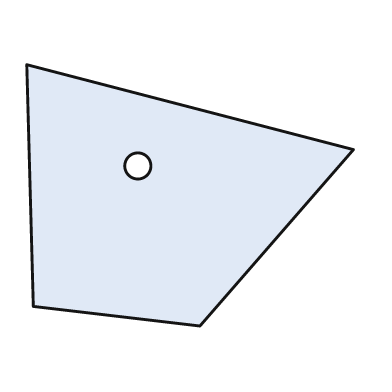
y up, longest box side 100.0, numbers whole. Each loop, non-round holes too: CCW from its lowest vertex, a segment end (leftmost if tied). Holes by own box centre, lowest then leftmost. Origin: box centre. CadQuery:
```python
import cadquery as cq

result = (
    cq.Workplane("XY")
    .moveTo(3.0, -40.0)
    .lineTo(50.0, 14.0)
    .lineTo(-50.0, 40.0)
    .lineTo(-48.0, -34.0)
    .close()
    .moveTo(-16.0, 9.0)
    .circle(4.0)
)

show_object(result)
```